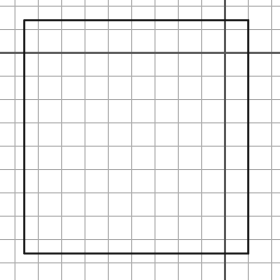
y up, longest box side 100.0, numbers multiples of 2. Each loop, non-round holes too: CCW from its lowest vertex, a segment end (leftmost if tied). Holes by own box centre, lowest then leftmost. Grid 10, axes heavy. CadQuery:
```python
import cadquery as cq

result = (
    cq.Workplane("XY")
    .moveTo(-86.0, -86.0)
    .lineTo(10.0, -86.0)
    .lineTo(10.0, 14.0)
    .lineTo(-86.0, 14.0)
    .close()
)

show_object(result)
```